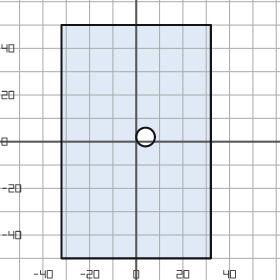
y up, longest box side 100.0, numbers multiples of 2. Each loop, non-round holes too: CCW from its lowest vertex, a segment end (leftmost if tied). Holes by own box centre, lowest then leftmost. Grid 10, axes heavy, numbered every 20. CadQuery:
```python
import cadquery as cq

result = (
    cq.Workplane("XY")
    .moveTo(-32.0, -50.0)
    .lineTo(32.0, -50.0)
    .lineTo(32.0, 50.0)
    .lineTo(-32.0, 50.0)
    .close()
    .moveTo(4.0, 2.0)
    .circle(4.0)
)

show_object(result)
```